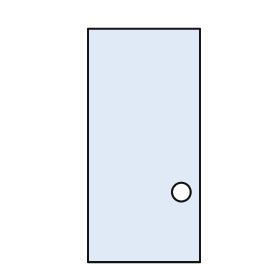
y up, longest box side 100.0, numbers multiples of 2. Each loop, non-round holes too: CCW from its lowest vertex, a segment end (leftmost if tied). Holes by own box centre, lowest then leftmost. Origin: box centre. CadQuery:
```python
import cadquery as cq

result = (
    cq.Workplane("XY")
    .moveTo(-24.0, -50.0)
    .lineTo(24.0, -50.0)
    .lineTo(24.0, 50.0)
    .lineTo(-24.0, 50.0)
    .close()
    .moveTo(16.0, -20.0)
    .circle(4.0)
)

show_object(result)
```